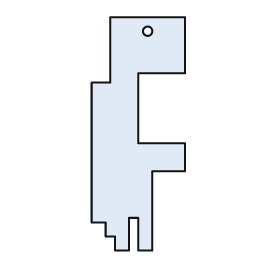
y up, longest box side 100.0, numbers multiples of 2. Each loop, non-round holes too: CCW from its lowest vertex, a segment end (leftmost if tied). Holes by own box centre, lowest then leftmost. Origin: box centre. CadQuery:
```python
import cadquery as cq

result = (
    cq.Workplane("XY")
    .moveTo(-10.0, -50.0)
    .lineTo(-4.0, -50.0)
    .lineTo(-4.0, -36.0)
    .lineTo(0.0, -36.0)
    .lineTo(0.0, -50.0)
    .lineTo(6.0, -50.0)
    .lineTo(6.0, -16.0)
    .lineTo(20.0, -16.0)
    .lineTo(20.0, -4.0)
    .lineTo(0.0, -4.0)
    .lineTo(0.0, 26.0)
    .lineTo(20.0, 26.0)
    .lineTo(20.0, 50.0)
    .lineTo(-12.0, 50.0)
    .lineTo(-12.0, 22.0)
    .lineTo(-20.0, 22.0)
    .lineTo(-20.0, -38.0)
    .lineTo(-14.0, -38.0)
    .lineTo(-14.0, -44.0)
    .lineTo(-10.0, -44.0)
    .close()
    .moveTo(4.0, 44.0)
    .circle(2.0)
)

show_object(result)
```